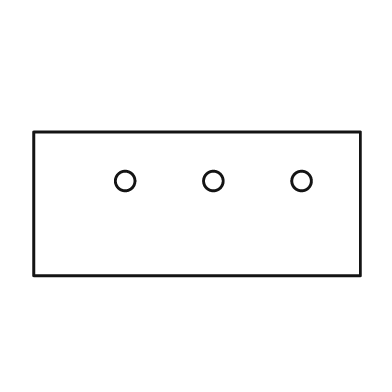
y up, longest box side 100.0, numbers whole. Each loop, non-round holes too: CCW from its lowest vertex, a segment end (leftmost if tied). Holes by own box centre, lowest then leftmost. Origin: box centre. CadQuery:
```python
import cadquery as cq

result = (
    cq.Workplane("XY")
    .moveTo(-50.0, -22.0)
    .lineTo(50.0, -22.0)
    .lineTo(50.0, 22.0)
    .lineTo(-50.0, 22.0)
    .close()
    .moveTo(-22.0, 7.0)
    .circle(3.0)
    .moveTo(5.0, 7.0)
    .circle(3.0)
    .moveTo(32.0, 7.0)
    .circle(3.0)
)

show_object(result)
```